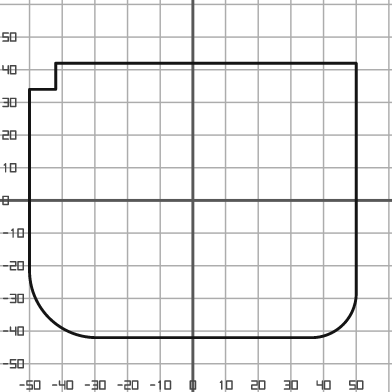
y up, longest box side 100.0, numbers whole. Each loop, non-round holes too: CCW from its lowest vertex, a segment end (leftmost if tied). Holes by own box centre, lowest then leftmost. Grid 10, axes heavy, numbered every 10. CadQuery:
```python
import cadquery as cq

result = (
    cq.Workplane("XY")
    .moveTo(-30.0, -42.0)
    .lineTo(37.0, -42.0)
    .threePointArc((46.0, -38.0), (50.0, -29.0))
    .lineTo(50.0, 42.0)
    .lineTo(-42.0, 42.0)
    .lineTo(-42.0, 34.0)
    .lineTo(-50.0, 34.0)
    .lineTo(-50.0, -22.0)
    .threePointArc((-44.0, -36.0), (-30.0, -42.0))
    .close()
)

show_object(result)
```